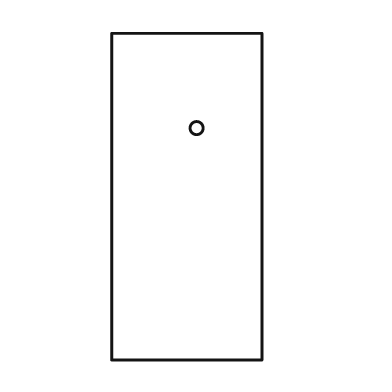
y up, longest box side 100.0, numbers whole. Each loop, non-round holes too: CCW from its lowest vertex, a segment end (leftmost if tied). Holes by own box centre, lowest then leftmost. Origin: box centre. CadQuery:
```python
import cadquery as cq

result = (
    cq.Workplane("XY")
    .moveTo(-23.0, -50.0)
    .lineTo(23.0, -50.0)
    .lineTo(23.0, 50.0)
    .lineTo(-23.0, 50.0)
    .close()
    .moveTo(3.0, 21.0)
    .circle(2.0)
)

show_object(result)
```